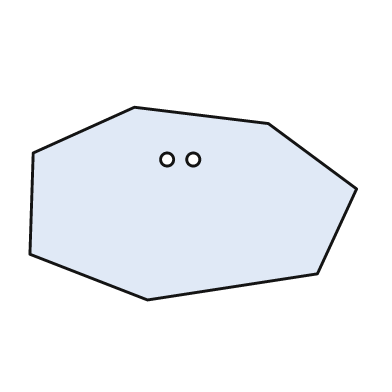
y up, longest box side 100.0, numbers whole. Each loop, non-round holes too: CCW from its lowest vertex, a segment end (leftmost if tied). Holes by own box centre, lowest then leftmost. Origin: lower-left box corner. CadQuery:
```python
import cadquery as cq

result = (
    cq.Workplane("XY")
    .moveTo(36.0, 0.0)
    .lineTo(88.0, 8.0)
    .lineTo(100.0, 34.0)
    .lineTo(73.0, 54.0)
    .lineTo(32.0, 59.0)
    .lineTo(1.0, 45.0)
    .lineTo(0.0, 14.0)
    .close()
    .moveTo(42.0, 43.0)
    .circle(2.0)
    .moveTo(50.0, 43.0)
    .circle(2.0)
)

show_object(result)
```